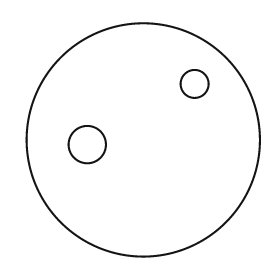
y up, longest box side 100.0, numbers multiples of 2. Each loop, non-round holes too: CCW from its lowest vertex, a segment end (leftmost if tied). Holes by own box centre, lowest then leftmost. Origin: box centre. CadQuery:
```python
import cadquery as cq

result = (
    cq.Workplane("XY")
    .moveTo(0.0, 0.0)
    .circle(50.0)
    .moveTo(-24.0, -2.0)
    .circle(8.0)
    .moveTo(22.0, 24.0)
    .circle(6.0)
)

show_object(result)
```